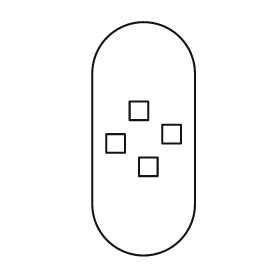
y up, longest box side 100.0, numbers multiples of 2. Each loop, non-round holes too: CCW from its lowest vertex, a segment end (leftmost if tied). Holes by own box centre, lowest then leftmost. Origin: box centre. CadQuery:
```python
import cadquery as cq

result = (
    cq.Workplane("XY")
    .moveTo(-22.0, -28.0)
    .threePointArc((0.0, -50.0), (22.0, -28.0))
    .lineTo(22.0, 28.0)
    .threePointArc((0.0, 50.0), (-22.0, 28.0))
    .close()
    .moveTo(-2.0, -16.0)
    .lineTo(6.0, -16.0)
    .lineTo(6.0, -8.0)
    .lineTo(-2.0, -8.0)
    .close()
    .moveTo(-16.0, -6.0)
    .lineTo(-8.0, -6.0)
    .lineTo(-8.0, 2.0)
    .lineTo(-16.0, 2.0)
    .close()
    .moveTo(8.0, -2.0)
    .lineTo(16.0, -2.0)
    .lineTo(16.0, 6.0)
    .lineTo(8.0, 6.0)
    .close()
    .moveTo(-6.0, 8.0)
    .lineTo(2.0, 8.0)
    .lineTo(2.0, 16.0)
    .lineTo(-6.0, 16.0)
    .close()
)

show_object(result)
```